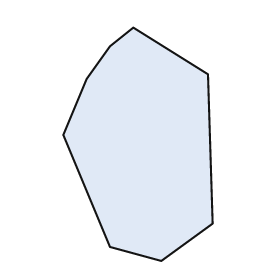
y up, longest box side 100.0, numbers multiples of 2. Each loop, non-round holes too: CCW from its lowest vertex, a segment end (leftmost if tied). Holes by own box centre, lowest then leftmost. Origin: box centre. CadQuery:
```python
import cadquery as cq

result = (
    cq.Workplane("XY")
    .moveTo(10.0, -50.0)
    .lineTo(32.0, -34.0)
    .lineTo(30.0, 30.0)
    .lineTo(-2.0, 50.0)
    .lineTo(-12.0, 42.0)
    .lineTo(-22.0, 28.0)
    .lineTo(-32.0, 4.0)
    .lineTo(-12.0, -44.0)
    .close()
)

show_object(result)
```